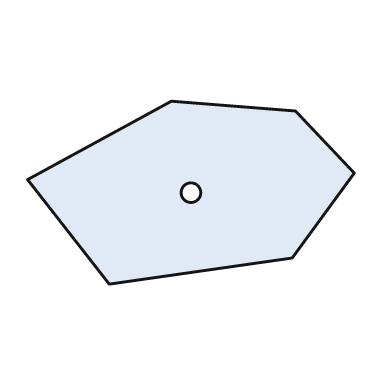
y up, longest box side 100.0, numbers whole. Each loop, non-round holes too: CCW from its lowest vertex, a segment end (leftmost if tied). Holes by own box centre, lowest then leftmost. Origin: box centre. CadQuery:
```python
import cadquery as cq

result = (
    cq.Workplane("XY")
    .moveTo(-25.0, -28.0)
    .lineTo(31.0, -20.0)
    .lineTo(50.0, 6.0)
    .lineTo(32.0, 25.0)
    .lineTo(-6.0, 28.0)
    .lineTo(-50.0, 4.0)
    .close()
    .moveTo(0.0, 0.0)
    .circle(3.0)
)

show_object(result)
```